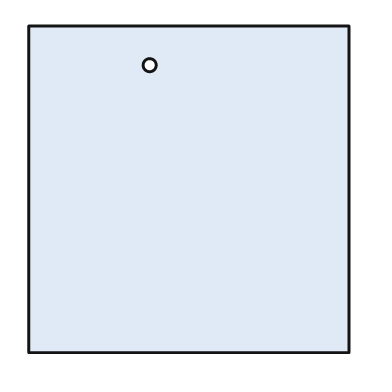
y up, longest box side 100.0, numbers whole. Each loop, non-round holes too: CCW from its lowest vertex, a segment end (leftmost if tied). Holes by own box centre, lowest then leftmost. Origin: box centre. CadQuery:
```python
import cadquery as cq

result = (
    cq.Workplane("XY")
    .moveTo(-49.0, -50.0)
    .lineTo(49.0, -50.0)
    .lineTo(49.0, 50.0)
    .lineTo(-49.0, 50.0)
    .close()
    .moveTo(-12.0, 38.0)
    .circle(2.0)
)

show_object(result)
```